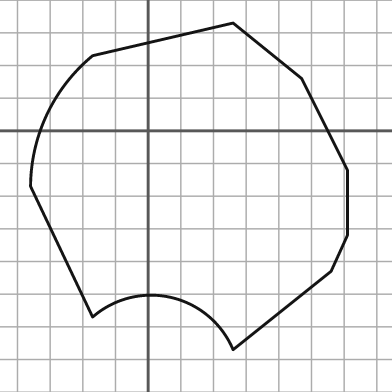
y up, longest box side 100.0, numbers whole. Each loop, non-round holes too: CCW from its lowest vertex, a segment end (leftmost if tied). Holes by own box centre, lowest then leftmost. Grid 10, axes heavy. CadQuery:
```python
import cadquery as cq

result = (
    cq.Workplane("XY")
    .moveTo(26.0, -67.0)
    .lineTo(56.0, -43.0)
    .lineTo(61.0, -32.0)
    .lineTo(61.0, -12.0)
    .lineTo(47.0, 16.0)
    .lineTo(26.0, 33.0)
    .lineTo(-17.0, 23.0)
    .threePointArc((-31.0, 5.0), (-36.0, -17.0))
    .lineTo(-17.0, -57.0)
    .threePointArc((7.0, -51.0), (26.0, -67.0))
    .close()
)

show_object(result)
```